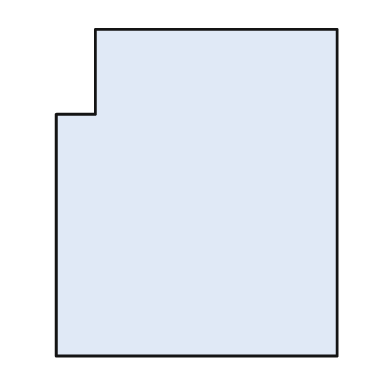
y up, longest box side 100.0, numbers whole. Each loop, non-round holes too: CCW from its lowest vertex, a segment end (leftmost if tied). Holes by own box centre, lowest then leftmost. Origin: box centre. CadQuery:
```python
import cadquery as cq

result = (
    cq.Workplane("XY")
    .moveTo(-43.0, -50.0)
    .lineTo(43.0, -50.0)
    .lineTo(43.0, 50.0)
    .lineTo(-31.0, 50.0)
    .lineTo(-31.0, 24.0)
    .lineTo(-43.0, 24.0)
    .close()
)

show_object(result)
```